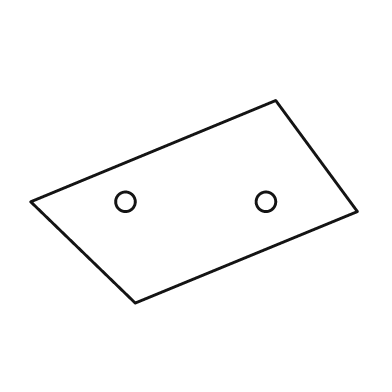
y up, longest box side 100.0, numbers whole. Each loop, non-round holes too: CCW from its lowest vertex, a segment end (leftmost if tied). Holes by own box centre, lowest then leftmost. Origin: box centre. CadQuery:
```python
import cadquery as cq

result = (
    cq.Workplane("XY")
    .moveTo(-18.0, -31.0)
    .lineTo(50.0, -3.0)
    .lineTo(25.0, 31.0)
    .lineTo(-50.0, 0.0)
    .close()
    .moveTo(-21.0, 0.0)
    .circle(3.0)
    .moveTo(22.0, 0.0)
    .circle(3.0)
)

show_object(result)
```